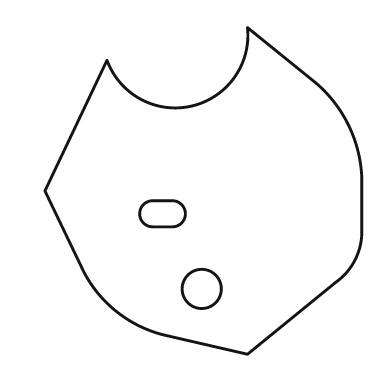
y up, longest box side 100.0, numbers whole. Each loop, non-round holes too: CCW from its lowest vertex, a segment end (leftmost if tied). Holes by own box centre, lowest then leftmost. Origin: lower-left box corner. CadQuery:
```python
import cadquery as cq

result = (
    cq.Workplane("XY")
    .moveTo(62.0, 0.0)
    .lineTo(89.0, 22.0)
    .threePointArc((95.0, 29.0), (97.0, 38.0))
    .lineTo(97.0, 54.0)
    .threePointArc((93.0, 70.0), (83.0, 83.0))
    .lineTo(62.0, 100.0)
    .threePointArc((45.0, 76.0), (19.0, 90.0))
    .lineTo(0.0, 50.0)
    .lineTo(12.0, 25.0)
    .threePointArc((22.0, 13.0), (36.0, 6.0))
    .close()
    .moveTo(48.0, 20.0)
    .circle(6.0)
    .moveTo(33.0, 39.0)
    .lineTo(39.0, 39.0)
    .threePointArc((43.0, 43.0), (39.0, 47.0))
    .lineTo(33.0, 47.0)
    .threePointArc((29.0, 43.0), (33.0, 39.0))
    .close()
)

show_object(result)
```